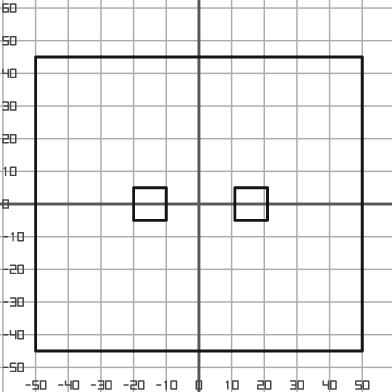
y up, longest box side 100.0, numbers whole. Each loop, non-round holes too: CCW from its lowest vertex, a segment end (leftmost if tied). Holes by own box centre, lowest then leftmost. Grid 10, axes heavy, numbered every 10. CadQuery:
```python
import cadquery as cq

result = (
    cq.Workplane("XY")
    .moveTo(-50.0, -45.0)
    .lineTo(50.0, -45.0)
    .lineTo(50.0, 45.0)
    .lineTo(-50.0, 45.0)
    .close()
    .moveTo(-20.0, -5.0)
    .lineTo(-10.0, -5.0)
    .lineTo(-10.0, 5.0)
    .lineTo(-20.0, 5.0)
    .close()
    .moveTo(11.0, -5.0)
    .lineTo(21.0, -5.0)
    .lineTo(21.0, 5.0)
    .lineTo(11.0, 5.0)
    .close()
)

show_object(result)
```